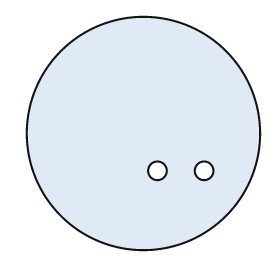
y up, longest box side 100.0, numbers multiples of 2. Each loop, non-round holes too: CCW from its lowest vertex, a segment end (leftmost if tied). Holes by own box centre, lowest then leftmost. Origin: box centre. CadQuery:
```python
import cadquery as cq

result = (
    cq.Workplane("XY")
    .moveTo(0.0, 0.0)
    .circle(50.0)
    .moveTo(6.0, -16.0)
    .circle(4.0)
    .moveTo(26.0, -16.0)
    .circle(4.0)
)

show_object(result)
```